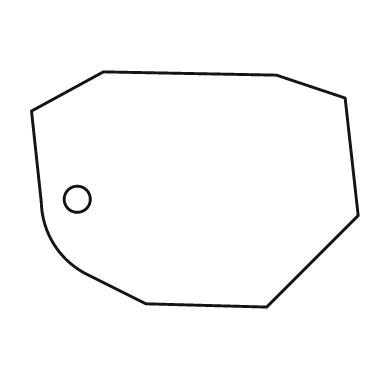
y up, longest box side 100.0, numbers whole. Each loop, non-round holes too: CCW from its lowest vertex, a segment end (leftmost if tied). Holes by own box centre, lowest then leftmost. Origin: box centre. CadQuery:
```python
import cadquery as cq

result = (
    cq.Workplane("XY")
    .moveTo(22.0, -36.0)
    .lineTo(50.0, -8.0)
    .lineTo(46.0, 28.0)
    .lineTo(25.0, 35.0)
    .lineTo(-28.0, 36.0)
    .lineTo(-50.0, 24.0)
    .lineTo(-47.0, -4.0)
    .threePointArc((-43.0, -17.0), (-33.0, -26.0))
    .lineTo(-15.0, -35.0)
    .close()
    .moveTo(-36.0, -3.0)
    .circle(4.0)
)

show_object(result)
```